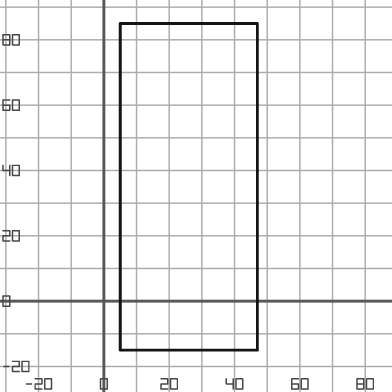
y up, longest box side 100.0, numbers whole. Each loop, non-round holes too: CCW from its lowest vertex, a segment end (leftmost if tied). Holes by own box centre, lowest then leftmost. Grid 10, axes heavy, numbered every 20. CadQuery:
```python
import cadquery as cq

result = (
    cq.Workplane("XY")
    .moveTo(5.0, -15.0)
    .lineTo(47.0, -15.0)
    .lineTo(47.0, 85.0)
    .lineTo(5.0, 85.0)
    .close()
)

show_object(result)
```